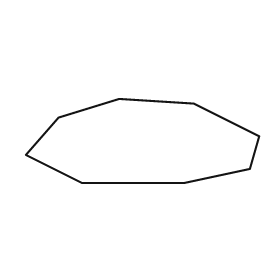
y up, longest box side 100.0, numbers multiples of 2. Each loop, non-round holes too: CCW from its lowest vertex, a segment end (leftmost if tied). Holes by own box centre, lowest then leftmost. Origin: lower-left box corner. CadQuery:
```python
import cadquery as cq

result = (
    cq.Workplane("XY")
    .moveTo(24.0, 0.0)
    .lineTo(68.0, 0.0)
    .lineTo(96.0, 6.0)
    .lineTo(100.0, 20.0)
    .lineTo(72.0, 34.0)
    .lineTo(40.0, 36.0)
    .lineTo(14.0, 28.0)
    .lineTo(0.0, 12.0)
    .close()
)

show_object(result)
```